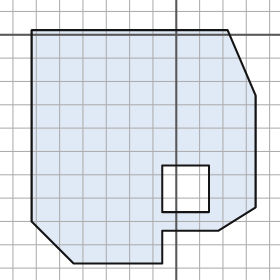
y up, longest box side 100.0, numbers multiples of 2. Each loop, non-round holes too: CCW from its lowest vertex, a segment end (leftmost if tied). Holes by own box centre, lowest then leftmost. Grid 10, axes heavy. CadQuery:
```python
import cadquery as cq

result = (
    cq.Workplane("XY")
    .moveTo(-44.0, -98.0)
    .lineTo(-6.0, -98.0)
    .lineTo(-6.0, -84.0)
    .lineTo(18.0, -84.0)
    .lineTo(34.0, -74.0)
    .lineTo(34.0, -26.0)
    .lineTo(22.0, 2.0)
    .lineTo(-62.0, 2.0)
    .lineTo(-62.0, -80.0)
    .close()
    .moveTo(-6.0, -76.0)
    .lineTo(14.0, -76.0)
    .lineTo(14.0, -56.0)
    .lineTo(-6.0, -56.0)
    .close()
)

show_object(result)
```